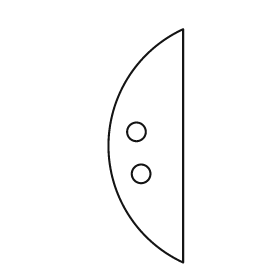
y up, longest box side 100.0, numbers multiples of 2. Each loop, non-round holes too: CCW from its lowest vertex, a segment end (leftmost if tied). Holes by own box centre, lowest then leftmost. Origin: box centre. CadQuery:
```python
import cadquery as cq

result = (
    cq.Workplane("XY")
    .moveTo(16.0, -50.0)
    .lineTo(16.0, 50.0)
    .threePointArc((-16.0, 0.0), (16.0, -50.0))
    .close()
    .moveTo(-2.0, -12.0)
    .circle(4.0)
    .moveTo(-4.0, 6.0)
    .circle(4.0)
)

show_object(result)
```